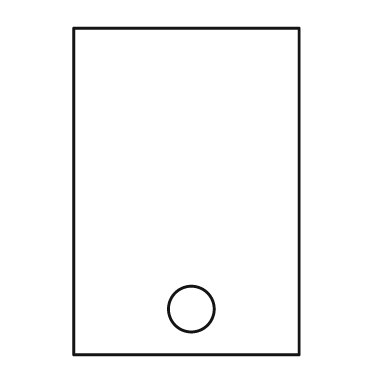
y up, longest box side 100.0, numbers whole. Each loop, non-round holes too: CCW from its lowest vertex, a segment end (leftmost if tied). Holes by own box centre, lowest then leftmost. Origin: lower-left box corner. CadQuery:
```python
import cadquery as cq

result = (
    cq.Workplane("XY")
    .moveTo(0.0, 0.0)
    .lineTo(69.0, 0.0)
    .lineTo(69.0, 100.0)
    .lineTo(0.0, 100.0)
    .close()
    .moveTo(36.0, 14.0)
    .circle(7.0)
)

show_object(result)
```